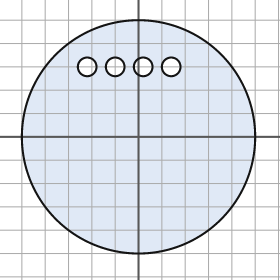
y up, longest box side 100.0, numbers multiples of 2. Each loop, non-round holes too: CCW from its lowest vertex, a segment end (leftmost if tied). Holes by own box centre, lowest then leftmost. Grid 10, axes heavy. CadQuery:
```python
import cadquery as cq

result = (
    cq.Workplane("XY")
    .moveTo(0.0, 0.0)
    .circle(50.0)
    .moveTo(-22.0, 30.0)
    .circle(4.0)
    .moveTo(-10.0, 30.0)
    .circle(4.0)
    .moveTo(2.0, 30.0)
    .circle(4.0)
    .moveTo(14.0, 30.0)
    .circle(4.0)
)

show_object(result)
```